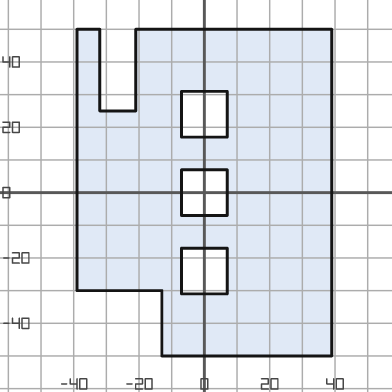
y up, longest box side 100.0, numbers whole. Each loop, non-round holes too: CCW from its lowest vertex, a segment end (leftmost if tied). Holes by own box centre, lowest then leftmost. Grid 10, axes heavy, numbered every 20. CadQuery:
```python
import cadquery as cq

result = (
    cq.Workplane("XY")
    .moveTo(-13.0, -50.0)
    .lineTo(39.0, -50.0)
    .lineTo(39.0, 50.0)
    .lineTo(-21.0, 50.0)
    .lineTo(-21.0, 25.0)
    .lineTo(-32.0, 25.0)
    .lineTo(-32.0, 50.0)
    .lineTo(-39.0, 50.0)
    .lineTo(-39.0, -30.0)
    .lineTo(-13.0, -30.0)
    .close()
    .moveTo(-7.0, -31.0)
    .lineTo(7.0, -31.0)
    .lineTo(7.0, -17.0)
    .lineTo(-7.0, -17.0)
    .close()
    .moveTo(-7.0, -7.0)
    .lineTo(7.0, -7.0)
    .lineTo(7.0, 7.0)
    .lineTo(-7.0, 7.0)
    .close()
    .moveTo(-7.0, 17.0)
    .lineTo(7.0, 17.0)
    .lineTo(7.0, 31.0)
    .lineTo(-7.0, 31.0)
    .close()
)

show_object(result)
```